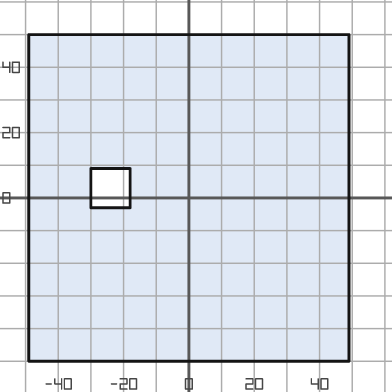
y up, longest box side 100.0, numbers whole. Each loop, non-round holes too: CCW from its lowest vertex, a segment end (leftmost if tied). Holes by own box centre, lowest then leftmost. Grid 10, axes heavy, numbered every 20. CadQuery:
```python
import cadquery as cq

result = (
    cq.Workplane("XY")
    .moveTo(-49.0, -50.0)
    .lineTo(49.0, -50.0)
    .lineTo(49.0, 50.0)
    .lineTo(-49.0, 50.0)
    .close()
    .moveTo(-30.0, -3.0)
    .lineTo(-18.0, -3.0)
    .lineTo(-18.0, 9.0)
    .lineTo(-30.0, 9.0)
    .close()
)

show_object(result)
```